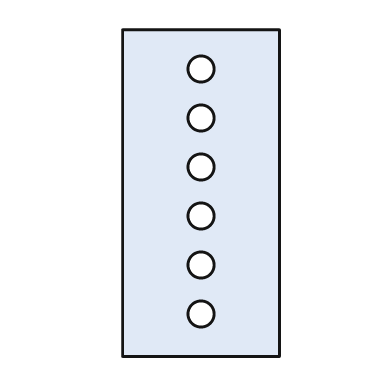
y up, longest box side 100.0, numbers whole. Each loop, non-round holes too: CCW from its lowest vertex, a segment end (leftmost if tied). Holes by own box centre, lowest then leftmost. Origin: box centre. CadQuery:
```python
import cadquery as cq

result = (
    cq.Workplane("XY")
    .moveTo(-24.0, -50.0)
    .lineTo(24.0, -50.0)
    .lineTo(24.0, 50.0)
    .lineTo(-24.0, 50.0)
    .close()
    .moveTo(0.0, -37.0)
    .circle(4.0)
    .moveTo(0.0, -22.0)
    .circle(4.0)
    .moveTo(0.0, -7.0)
    .circle(4.0)
    .moveTo(0.0, 8.0)
    .circle(4.0)
    .moveTo(0.0, 23.0)
    .circle(4.0)
    .moveTo(0.0, 38.0)
    .circle(4.0)
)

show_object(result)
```